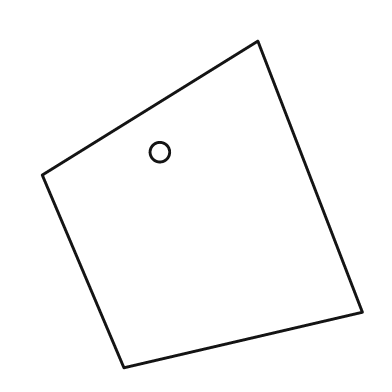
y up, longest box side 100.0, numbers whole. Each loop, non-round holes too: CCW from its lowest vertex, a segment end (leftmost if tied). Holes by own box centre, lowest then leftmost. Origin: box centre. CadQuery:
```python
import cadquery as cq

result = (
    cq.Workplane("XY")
    .moveTo(-24.0, -50.0)
    .lineTo(49.0, -33.0)
    .lineTo(17.0, 50.0)
    .lineTo(-49.0, 9.0)
    .close()
    .moveTo(-13.0, 16.0)
    .circle(3.0)
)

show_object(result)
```